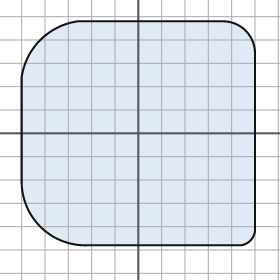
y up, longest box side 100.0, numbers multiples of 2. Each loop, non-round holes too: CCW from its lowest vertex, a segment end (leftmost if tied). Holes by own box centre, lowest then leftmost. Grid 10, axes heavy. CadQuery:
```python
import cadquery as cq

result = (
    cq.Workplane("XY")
    .moveTo(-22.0, -48.0)
    .lineTo(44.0, -48.0)
    .threePointArc((48.0, -46.0), (50.0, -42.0))
    .lineTo(50.0, 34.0)
    .threePointArc((46.0, 44.0), (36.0, 48.0))
    .lineTo(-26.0, 48.0)
    .threePointArc((-42.0, 40.0), (-50.0, 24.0))
    .lineTo(-50.0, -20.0)
    .threePointArc((-42.0, -40.0), (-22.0, -48.0))
    .close()
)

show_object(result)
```